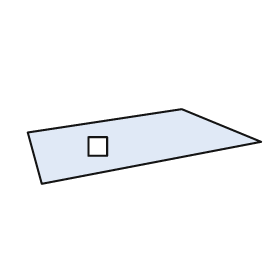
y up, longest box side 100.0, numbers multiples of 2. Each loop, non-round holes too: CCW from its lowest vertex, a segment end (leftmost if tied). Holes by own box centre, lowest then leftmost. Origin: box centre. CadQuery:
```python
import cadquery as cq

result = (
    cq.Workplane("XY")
    .moveTo(-44.0, -16.0)
    .lineTo(50.0, 2.0)
    .lineTo(16.0, 16.0)
    .lineTo(-50.0, 6.0)
    .close()
    .moveTo(-24.0, -4.0)
    .lineTo(-16.0, -4.0)
    .lineTo(-16.0, 4.0)
    .lineTo(-24.0, 4.0)
    .close()
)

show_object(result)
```